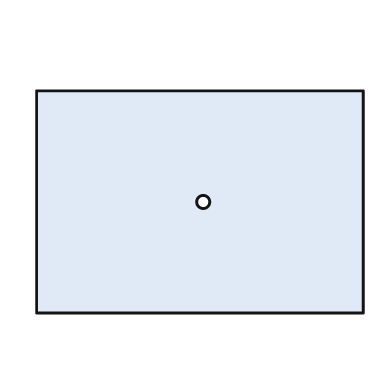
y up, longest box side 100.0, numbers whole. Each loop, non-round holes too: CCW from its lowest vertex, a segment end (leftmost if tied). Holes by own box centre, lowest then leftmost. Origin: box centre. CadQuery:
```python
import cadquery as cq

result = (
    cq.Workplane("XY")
    .moveTo(-50.0, -34.0)
    .lineTo(50.0, -34.0)
    .lineTo(50.0, 34.0)
    .lineTo(-50.0, 34.0)
    .close()
    .moveTo(1.0, 0.0)
    .circle(2.0)
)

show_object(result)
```